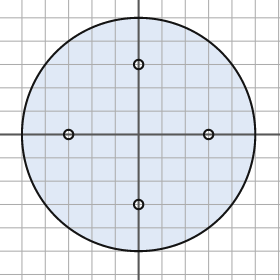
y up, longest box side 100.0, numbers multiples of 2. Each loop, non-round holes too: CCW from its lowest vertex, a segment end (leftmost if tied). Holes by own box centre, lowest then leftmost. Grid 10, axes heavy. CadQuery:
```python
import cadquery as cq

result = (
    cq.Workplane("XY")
    .moveTo(0.0, 0.0)
    .circle(50.0)
    .moveTo(0.0, -30.0)
    .circle(2.0)
    .moveTo(-30.0, 0.0)
    .circle(2.0)
    .moveTo(30.0, 0.0)
    .circle(2.0)
    .moveTo(0.0, 30.0)
    .circle(2.0)
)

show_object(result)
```